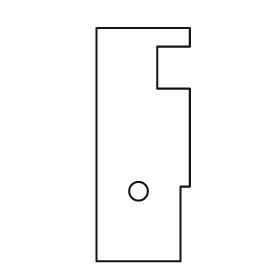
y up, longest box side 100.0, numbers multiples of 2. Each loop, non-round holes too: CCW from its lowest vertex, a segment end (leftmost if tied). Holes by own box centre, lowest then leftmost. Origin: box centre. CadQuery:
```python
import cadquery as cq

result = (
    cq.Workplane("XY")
    .moveTo(-20.0, -50.0)
    .lineTo(16.0, -50.0)
    .lineTo(16.0, -18.0)
    .lineTo(20.0, -18.0)
    .lineTo(20.0, 24.0)
    .lineTo(6.0, 24.0)
    .lineTo(6.0, 42.0)
    .lineTo(20.0, 42.0)
    .lineTo(20.0, 50.0)
    .lineTo(-20.0, 50.0)
    .close()
    .moveTo(-2.0, -20.0)
    .circle(4.0)
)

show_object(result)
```